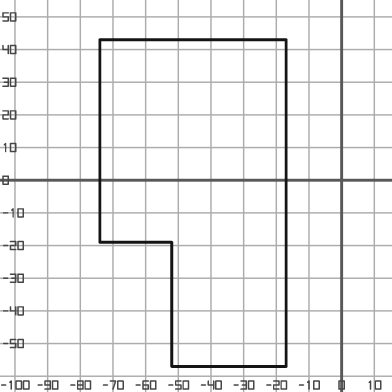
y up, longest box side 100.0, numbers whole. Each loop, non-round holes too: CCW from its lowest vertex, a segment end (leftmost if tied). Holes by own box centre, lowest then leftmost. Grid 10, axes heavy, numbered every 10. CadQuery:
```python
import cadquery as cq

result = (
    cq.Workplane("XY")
    .moveTo(-52.0, -57.0)
    .lineTo(-17.0, -57.0)
    .lineTo(-17.0, 43.0)
    .lineTo(-74.0, 43.0)
    .lineTo(-74.0, -19.0)
    .lineTo(-52.0, -19.0)
    .close()
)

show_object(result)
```